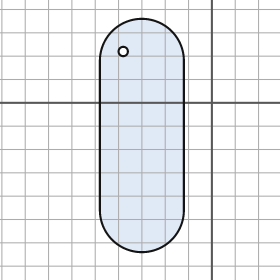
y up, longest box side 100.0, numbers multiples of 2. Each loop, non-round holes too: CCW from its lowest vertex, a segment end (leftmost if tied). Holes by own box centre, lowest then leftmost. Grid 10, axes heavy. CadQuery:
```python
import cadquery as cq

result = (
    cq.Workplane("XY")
    .moveTo(-48.0, -46.0)
    .threePointArc((-30.0, -64.0), (-12.0, -46.0))
    .lineTo(-12.0, 18.0)
    .threePointArc((-30.0, 36.0), (-48.0, 18.0))
    .close()
    .moveTo(-38.0, 22.0)
    .circle(2.0)
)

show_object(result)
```